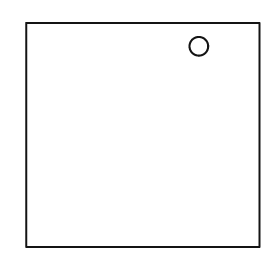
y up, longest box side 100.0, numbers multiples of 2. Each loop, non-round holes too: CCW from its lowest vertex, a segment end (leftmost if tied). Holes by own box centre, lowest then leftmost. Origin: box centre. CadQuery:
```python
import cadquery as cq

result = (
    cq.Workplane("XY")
    .moveTo(-50.0, -48.0)
    .lineTo(50.0, -48.0)
    .lineTo(50.0, 48.0)
    .lineTo(-50.0, 48.0)
    .close()
    .moveTo(24.0, 38.0)
    .circle(4.0)
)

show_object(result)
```